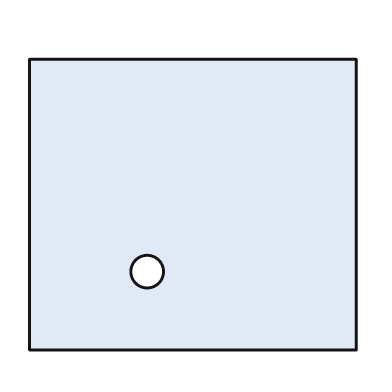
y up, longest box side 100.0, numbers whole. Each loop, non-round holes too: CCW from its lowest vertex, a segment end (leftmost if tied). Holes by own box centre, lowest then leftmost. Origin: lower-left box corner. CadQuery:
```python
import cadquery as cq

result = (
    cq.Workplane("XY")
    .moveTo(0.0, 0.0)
    .lineTo(100.0, 0.0)
    .lineTo(100.0, 89.0)
    .lineTo(0.0, 89.0)
    .close()
    .moveTo(36.0, 24.0)
    .circle(5.0)
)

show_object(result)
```